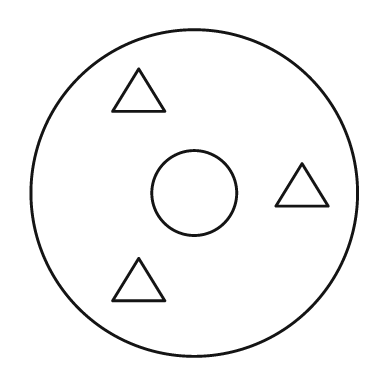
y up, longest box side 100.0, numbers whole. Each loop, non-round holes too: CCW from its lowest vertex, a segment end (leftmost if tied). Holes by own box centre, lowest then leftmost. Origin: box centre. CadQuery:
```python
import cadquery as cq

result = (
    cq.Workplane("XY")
    .moveTo(0.0, 0.0)
    .circle(50.0)
    .moveTo(-25.0, -33.0)
    .lineTo(-9.0, -33.0)
    .lineTo(-17.0, -20.0)
    .close()
    .moveTo(0.0, 0.0)
    .circle(13.0)
    .moveTo(25.0, -4.0)
    .lineTo(41.0, -4.0)
    .lineTo(33.0, 9.0)
    .close()
    .moveTo(-25.0, 25.0)
    .lineTo(-9.0, 25.0)
    .lineTo(-17.0, 38.0)
    .close()
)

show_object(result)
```